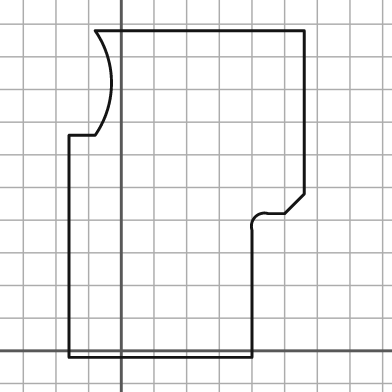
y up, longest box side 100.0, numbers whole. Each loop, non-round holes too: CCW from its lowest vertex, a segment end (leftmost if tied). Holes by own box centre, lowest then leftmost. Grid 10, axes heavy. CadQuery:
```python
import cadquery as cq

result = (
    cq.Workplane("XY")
    .moveTo(-16.0, -2.0)
    .lineTo(40.0, -2.0)
    .lineTo(40.0, 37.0)
    .threePointArc((41.0, 41.0), (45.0, 42.0))
    .lineTo(50.0, 42.0)
    .lineTo(56.0, 48.0)
    .lineTo(56.0, 98.0)
    .lineTo(-8.0, 98.0)
    .threePointArc((-3.0, 82.0), (-8.0, 66.0))
    .lineTo(-16.0, 66.0)
    .close()
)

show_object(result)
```